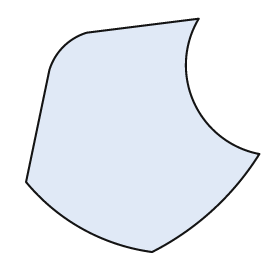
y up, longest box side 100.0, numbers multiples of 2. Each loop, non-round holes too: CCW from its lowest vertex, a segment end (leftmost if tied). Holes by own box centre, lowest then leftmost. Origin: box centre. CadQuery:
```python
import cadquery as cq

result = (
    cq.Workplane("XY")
    .moveTo(4.0, -50.0)
    .threePointArc((30.0, -32.0), (50.0, -8.0))
    .threePointArc((22.0, 14.0), (24.0, 50.0))
    .lineTo(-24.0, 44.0)
    .threePointArc((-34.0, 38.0), (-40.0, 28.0))
    .lineTo(-50.0, -20.0)
    .threePointArc((-26.0, -40.0), (4.0, -50.0))
    .close()
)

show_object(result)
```